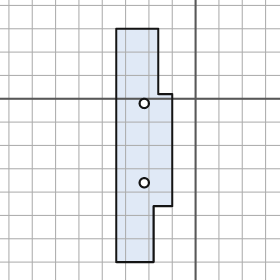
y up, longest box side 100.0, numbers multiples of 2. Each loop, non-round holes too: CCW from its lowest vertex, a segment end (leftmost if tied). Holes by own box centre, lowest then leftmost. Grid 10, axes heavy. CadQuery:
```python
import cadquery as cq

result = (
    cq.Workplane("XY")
    .moveTo(-34.0, -70.0)
    .lineTo(-18.0, -70.0)
    .lineTo(-18.0, -46.0)
    .lineTo(-10.0, -46.0)
    .lineTo(-10.0, 2.0)
    .lineTo(-16.0, 2.0)
    .lineTo(-16.0, 30.0)
    .lineTo(-34.0, 30.0)
    .close()
    .moveTo(-22.0, -36.0)
    .circle(2.0)
    .moveTo(-22.0, -2.0)
    .circle(2.0)
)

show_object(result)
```